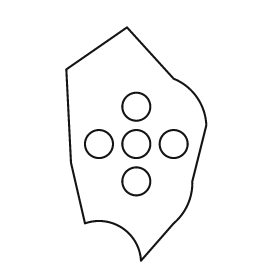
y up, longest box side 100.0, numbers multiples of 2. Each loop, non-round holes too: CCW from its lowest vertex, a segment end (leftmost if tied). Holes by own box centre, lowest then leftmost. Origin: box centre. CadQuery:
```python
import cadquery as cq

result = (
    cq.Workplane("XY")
    .moveTo(2.0, -50.0)
    .lineTo(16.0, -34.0)
    .threePointArc((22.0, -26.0), (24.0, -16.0))
    .lineTo(30.0, 8.0)
    .threePointArc((26.0, 20.0), (16.0, 28.0))
    .lineTo(-4.0, 50.0)
    .lineTo(-30.0, 32.0)
    .lineTo(-28.0, -8.0)
    .lineTo(-22.0, -34.0)
    .threePointArc((-6.0, -36.0), (2.0, -50.0))
    .close()
    .moveTo(0.0, -16.0)
    .circle(6.0)
    .moveTo(-16.0, 0.0)
    .circle(6.0)
    .moveTo(0.0, 0.0)
    .circle(6.0)
    .moveTo(16.0, 0.0)
    .circle(6.0)
    .moveTo(0.0, 16.0)
    .circle(6.0)
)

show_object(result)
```